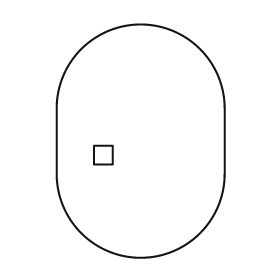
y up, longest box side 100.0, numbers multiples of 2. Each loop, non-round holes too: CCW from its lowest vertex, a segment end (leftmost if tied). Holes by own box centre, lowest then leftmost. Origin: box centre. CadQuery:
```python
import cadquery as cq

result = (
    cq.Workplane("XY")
    .moveTo(-36.0, -14.0)
    .threePointArc((0.0, -50.0), (36.0, -14.0))
    .lineTo(36.0, 14.0)
    .threePointArc((0.0, 50.0), (-36.0, 14.0))
    .close()
    .moveTo(-20.0, -10.0)
    .lineTo(-12.0, -10.0)
    .lineTo(-12.0, -2.0)
    .lineTo(-20.0, -2.0)
    .close()
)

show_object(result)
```